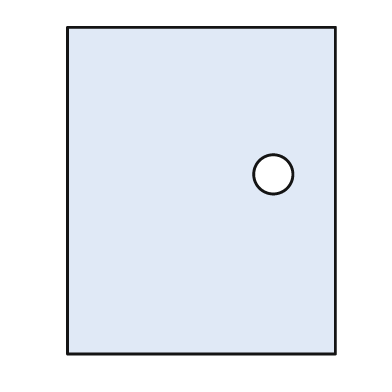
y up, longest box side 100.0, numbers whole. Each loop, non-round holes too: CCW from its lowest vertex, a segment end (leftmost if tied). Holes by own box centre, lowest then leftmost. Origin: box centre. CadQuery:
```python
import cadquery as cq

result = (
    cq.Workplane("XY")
    .moveTo(-41.0, -50.0)
    .lineTo(41.0, -50.0)
    .lineTo(41.0, 50.0)
    .lineTo(-41.0, 50.0)
    .close()
    .moveTo(22.0, 5.0)
    .circle(6.0)
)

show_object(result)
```